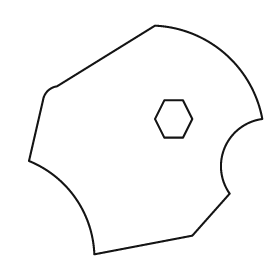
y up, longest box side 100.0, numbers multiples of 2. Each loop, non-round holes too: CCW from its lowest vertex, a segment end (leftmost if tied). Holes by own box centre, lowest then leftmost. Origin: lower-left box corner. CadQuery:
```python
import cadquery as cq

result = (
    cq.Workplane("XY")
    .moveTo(28.0, 0.0)
    .lineTo(70.0, 8.0)
    .lineTo(86.0, 26.0)
    .threePointArc((84.0, 46.0), (100.0, 58.0))
    .threePointArc((84.0, 86.0), (54.0, 98.0))
    .lineTo(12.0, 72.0)
    .threePointArc((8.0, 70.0), (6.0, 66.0))
    .lineTo(0.0, 40.0)
    .threePointArc((20.0, 24.0), (28.0, 0.0))
    .close()
    .moveTo(58.0, 50.0)
    .lineTo(66.0, 50.0)
    .lineTo(70.0, 58.0)
    .lineTo(66.0, 66.0)
    .lineTo(58.0, 66.0)
    .lineTo(54.0, 58.0)
    .close()
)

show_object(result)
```